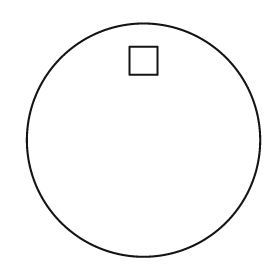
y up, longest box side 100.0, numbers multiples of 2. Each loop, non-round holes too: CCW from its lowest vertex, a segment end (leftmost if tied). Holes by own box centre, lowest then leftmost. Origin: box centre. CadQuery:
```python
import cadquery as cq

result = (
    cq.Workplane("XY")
    .moveTo(0.0, 0.0)
    .circle(50.0)
    .moveTo(-6.0, 28.0)
    .lineTo(6.0, 28.0)
    .lineTo(6.0, 40.0)
    .lineTo(-6.0, 40.0)
    .close()
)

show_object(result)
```